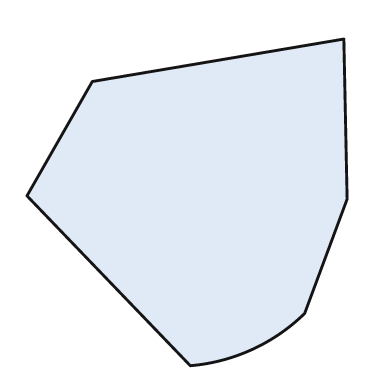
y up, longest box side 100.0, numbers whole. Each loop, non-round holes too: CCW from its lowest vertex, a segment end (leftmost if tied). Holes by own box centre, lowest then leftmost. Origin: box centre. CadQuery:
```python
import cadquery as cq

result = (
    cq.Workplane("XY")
    .moveTo(1.0, -50.0)
    .threePointArc((20.0, -45.0), (36.0, -34.0))
    .lineTo(49.0, 1.0)
    .lineTo(48.0, 50.0)
    .lineTo(-29.0, 37.0)
    .lineTo(-49.0, 2.0)
    .close()
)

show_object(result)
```